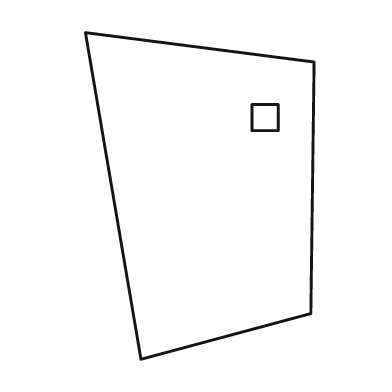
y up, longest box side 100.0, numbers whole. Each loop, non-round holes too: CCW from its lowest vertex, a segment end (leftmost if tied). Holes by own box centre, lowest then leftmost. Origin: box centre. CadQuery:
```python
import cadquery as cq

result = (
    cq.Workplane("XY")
    .moveTo(-18.0, -50.0)
    .lineTo(34.0, -36.0)
    .lineTo(35.0, 41.0)
    .lineTo(-35.0, 50.0)
    .close()
    .moveTo(16.0, 20.0)
    .lineTo(24.0, 20.0)
    .lineTo(24.0, 28.0)
    .lineTo(16.0, 28.0)
    .close()
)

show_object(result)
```